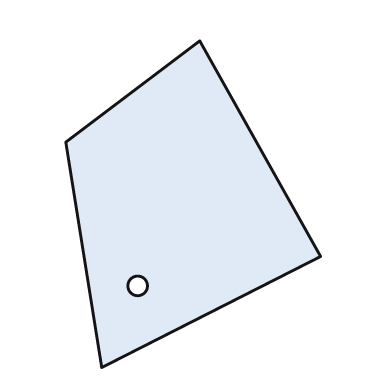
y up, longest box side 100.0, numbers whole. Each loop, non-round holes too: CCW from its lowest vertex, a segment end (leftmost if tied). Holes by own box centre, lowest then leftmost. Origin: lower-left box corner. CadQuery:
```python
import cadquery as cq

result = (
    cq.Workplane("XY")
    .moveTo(11.0, 0.0)
    .lineTo(78.0, 34.0)
    .lineTo(41.0, 100.0)
    .lineTo(0.0, 69.0)
    .close()
    .moveTo(22.0, 25.0)
    .circle(3.0)
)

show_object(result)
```